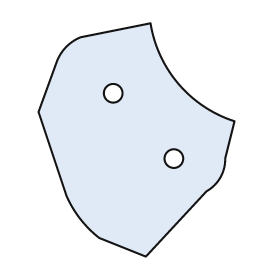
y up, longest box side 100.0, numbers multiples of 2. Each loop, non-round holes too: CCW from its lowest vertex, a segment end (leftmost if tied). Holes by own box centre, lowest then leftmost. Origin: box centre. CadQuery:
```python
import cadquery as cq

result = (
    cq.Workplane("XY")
    .moveTo(4.0, -50.0)
    .lineTo(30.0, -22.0)
    .threePointArc((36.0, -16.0), (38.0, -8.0))
    .lineTo(42.0, 8.0)
    .threePointArc((18.0, 24.0), (6.0, 50.0))
    .lineTo(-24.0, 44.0)
    .threePointArc((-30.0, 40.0), (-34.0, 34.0))
    .lineTo(-42.0, 12.0)
    .lineTo(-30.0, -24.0)
    .threePointArc((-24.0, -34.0), (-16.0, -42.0))
    .close()
    .moveTo(16.0, -8.0)
    .circle(4.0)
    .moveTo(-10.0, 20.0)
    .circle(4.0)
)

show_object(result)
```